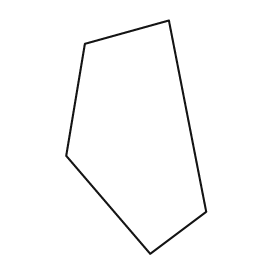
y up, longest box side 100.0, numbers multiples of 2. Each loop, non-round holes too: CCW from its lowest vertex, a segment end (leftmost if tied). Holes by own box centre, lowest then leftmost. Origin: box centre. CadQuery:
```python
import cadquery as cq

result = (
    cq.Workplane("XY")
    .moveTo(6.0, -50.0)
    .lineTo(30.0, -32.0)
    .lineTo(14.0, 50.0)
    .lineTo(-22.0, 40.0)
    .lineTo(-30.0, -8.0)
    .close()
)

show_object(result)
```